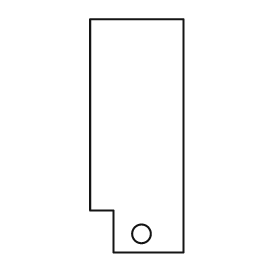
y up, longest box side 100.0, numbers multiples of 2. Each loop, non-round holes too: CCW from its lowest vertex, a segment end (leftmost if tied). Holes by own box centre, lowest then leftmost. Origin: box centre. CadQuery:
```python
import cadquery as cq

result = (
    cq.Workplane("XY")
    .moveTo(-10.0, -50.0)
    .lineTo(20.0, -50.0)
    .lineTo(20.0, 50.0)
    .lineTo(-20.0, 50.0)
    .lineTo(-20.0, -32.0)
    .lineTo(-10.0, -32.0)
    .close()
    .moveTo(2.0, -42.0)
    .circle(4.0)
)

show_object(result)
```